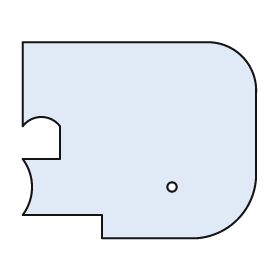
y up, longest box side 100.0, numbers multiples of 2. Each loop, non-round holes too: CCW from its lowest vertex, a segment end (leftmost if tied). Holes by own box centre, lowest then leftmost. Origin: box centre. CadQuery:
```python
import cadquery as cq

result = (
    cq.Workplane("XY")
    .moveTo(-16.0, -42.0)
    .lineTo(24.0, -42.0)
    .threePointArc((42.0, -34.0), (50.0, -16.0))
    .lineTo(50.0, 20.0)
    .threePointArc((44.0, 36.0), (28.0, 42.0))
    .lineTo(-50.0, 42.0)
    .lineTo(-50.0, 6.0)
    .threePointArc((-42.0, 10.0), (-34.0, 6.0))
    .lineTo(-34.0, -8.0)
    .lineTo(-50.0, -8.0)
    .threePointArc((-46.0, -20.0), (-50.0, -32.0))
    .lineTo(-16.0, -32.0)
    .close()
    .moveTo(14.0, -20.0)
    .circle(2.0)
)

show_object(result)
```